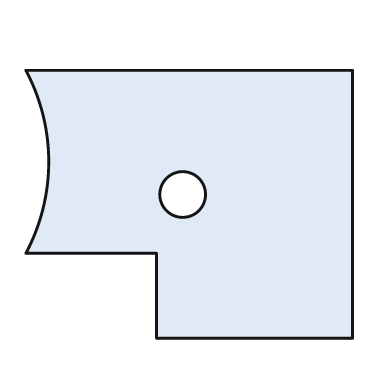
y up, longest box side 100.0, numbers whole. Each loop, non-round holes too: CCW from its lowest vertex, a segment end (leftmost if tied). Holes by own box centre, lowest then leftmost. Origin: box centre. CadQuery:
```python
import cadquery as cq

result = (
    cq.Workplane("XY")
    .moveTo(-10.0, -41.0)
    .lineTo(50.0, -41.0)
    .lineTo(50.0, 41.0)
    .lineTo(-50.0, 41.0)
    .threePointArc((-43.0, 13.0), (-50.0, -15.0))
    .lineTo(-10.0, -15.0)
    .close()
    .moveTo(-2.0, 3.0)
    .circle(7.0)
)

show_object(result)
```